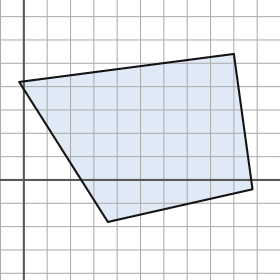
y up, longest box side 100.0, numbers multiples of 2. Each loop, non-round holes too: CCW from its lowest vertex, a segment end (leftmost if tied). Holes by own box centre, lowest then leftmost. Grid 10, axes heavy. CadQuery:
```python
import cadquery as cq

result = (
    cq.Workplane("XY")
    .moveTo(36.0, -18.0)
    .lineTo(98.0, -4.0)
    .lineTo(90.0, 54.0)
    .lineTo(-2.0, 42.0)
    .close()
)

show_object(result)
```